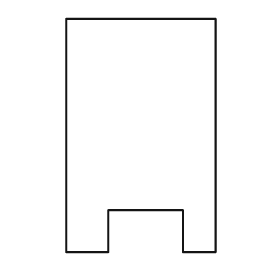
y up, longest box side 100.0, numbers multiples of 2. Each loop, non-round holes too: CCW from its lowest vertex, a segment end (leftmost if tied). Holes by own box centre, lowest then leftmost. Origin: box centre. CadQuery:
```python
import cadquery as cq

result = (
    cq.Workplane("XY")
    .moveTo(-32.0, -50.0)
    .lineTo(-14.0, -50.0)
    .lineTo(-14.0, -32.0)
    .lineTo(18.0, -32.0)
    .lineTo(18.0, -50.0)
    .lineTo(32.0, -50.0)
    .lineTo(32.0, 50.0)
    .lineTo(-32.0, 50.0)
    .close()
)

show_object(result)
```